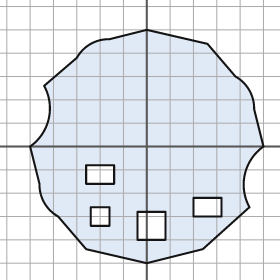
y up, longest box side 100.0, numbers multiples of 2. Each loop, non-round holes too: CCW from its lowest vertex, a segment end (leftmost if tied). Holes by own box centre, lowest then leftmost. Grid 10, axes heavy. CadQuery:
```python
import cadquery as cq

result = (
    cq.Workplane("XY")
    .moveTo(0.0, -50.0)
    .lineTo(24.0, -44.0)
    .lineTo(44.0, -26.0)
    .threePointArc((42.0, -12.0), (50.0, 0.0))
    .lineTo(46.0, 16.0)
    .threePointArc((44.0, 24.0), (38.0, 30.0))
    .lineTo(26.0, 44.0)
    .lineTo(0.0, 50.0)
    .lineTo(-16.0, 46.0)
    .threePointArc((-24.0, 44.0), (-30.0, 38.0))
    .lineTo(-44.0, 26.0)
    .threePointArc((-42.0, 12.0), (-50.0, 0.0))
    .lineTo(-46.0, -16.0)
    .threePointArc((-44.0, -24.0), (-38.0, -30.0))
    .lineTo(-26.0, -44.0)
    .close()
    .moveTo(-4.0, -40.0)
    .lineTo(8.0, -40.0)
    .lineTo(8.0, -28.0)
    .lineTo(-4.0, -28.0)
    .close()
    .moveTo(-24.0, -34.0)
    .lineTo(-16.0, -34.0)
    .lineTo(-16.0, -26.0)
    .lineTo(-24.0, -26.0)
    .close()
    .moveTo(20.0, -30.0)
    .lineTo(32.0, -30.0)
    .lineTo(32.0, -22.0)
    .lineTo(20.0, -22.0)
    .close()
    .moveTo(-26.0, -16.0)
    .lineTo(-14.0, -16.0)
    .lineTo(-14.0, -8.0)
    .lineTo(-26.0, -8.0)
    .close()
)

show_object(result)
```